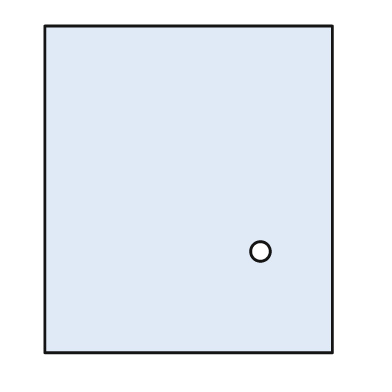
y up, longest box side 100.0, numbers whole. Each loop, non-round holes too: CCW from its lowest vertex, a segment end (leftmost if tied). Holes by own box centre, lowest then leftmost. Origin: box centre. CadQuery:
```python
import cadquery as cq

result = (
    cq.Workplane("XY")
    .moveTo(-44.0, -50.0)
    .lineTo(44.0, -50.0)
    .lineTo(44.0, 50.0)
    .lineTo(-44.0, 50.0)
    .close()
    .moveTo(22.0, -19.0)
    .circle(3.0)
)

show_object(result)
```